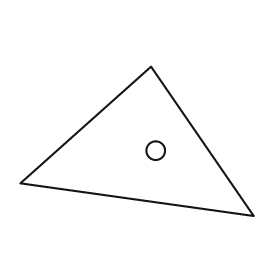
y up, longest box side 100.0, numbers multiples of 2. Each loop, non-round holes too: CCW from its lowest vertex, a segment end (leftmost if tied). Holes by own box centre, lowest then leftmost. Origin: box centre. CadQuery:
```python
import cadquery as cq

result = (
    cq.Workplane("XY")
    .moveTo(50.0, -32.0)
    .lineTo(6.0, 32.0)
    .lineTo(-50.0, -18.0)
    .close()
    .moveTo(8.0, -4.0)
    .circle(4.0)
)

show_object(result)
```